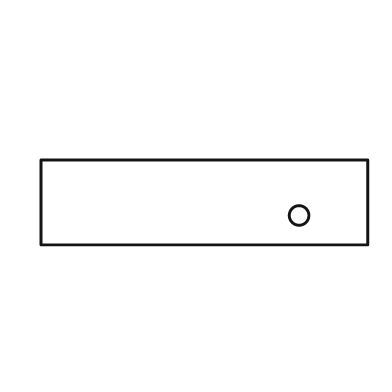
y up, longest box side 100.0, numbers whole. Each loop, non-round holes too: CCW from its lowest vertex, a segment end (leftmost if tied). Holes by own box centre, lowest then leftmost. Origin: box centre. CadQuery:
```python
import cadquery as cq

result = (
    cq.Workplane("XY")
    .moveTo(-50.0, -13.0)
    .lineTo(50.0, -13.0)
    .lineTo(50.0, 13.0)
    .lineTo(-50.0, 13.0)
    .close()
    .moveTo(29.0, -4.0)
    .circle(3.0)
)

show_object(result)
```